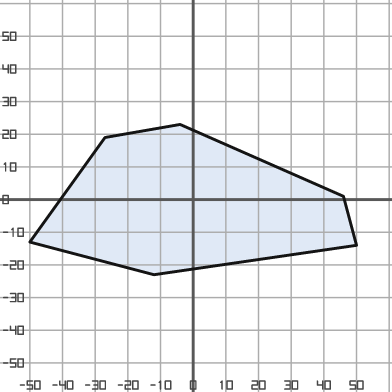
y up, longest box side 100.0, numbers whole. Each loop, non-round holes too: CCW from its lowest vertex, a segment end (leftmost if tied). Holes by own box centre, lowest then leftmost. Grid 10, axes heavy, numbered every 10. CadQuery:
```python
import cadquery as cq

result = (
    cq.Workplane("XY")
    .moveTo(-12.0, -23.0)
    .lineTo(50.0, -14.0)
    .lineTo(46.0, 1.0)
    .lineTo(-4.0, 23.0)
    .lineTo(-27.0, 19.0)
    .lineTo(-50.0, -13.0)
    .close()
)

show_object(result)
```